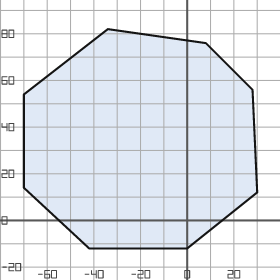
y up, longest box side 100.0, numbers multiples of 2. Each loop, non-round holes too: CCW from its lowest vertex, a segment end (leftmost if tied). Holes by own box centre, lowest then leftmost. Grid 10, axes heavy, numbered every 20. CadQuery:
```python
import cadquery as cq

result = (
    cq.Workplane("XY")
    .moveTo(-42.0, -12.0)
    .lineTo(0.0, -12.0)
    .lineTo(30.0, 12.0)
    .lineTo(28.0, 56.0)
    .lineTo(8.0, 76.0)
    .lineTo(-34.0, 82.0)
    .lineTo(-70.0, 54.0)
    .lineTo(-70.0, 14.0)
    .close()
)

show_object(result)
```